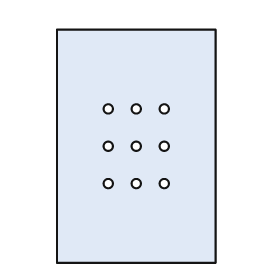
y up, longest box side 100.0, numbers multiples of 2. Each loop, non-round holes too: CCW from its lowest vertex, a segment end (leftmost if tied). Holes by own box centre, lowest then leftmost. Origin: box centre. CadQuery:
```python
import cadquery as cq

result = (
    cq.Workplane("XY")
    .moveTo(-34.0, -50.0)
    .lineTo(34.0, -50.0)
    .lineTo(34.0, 50.0)
    .lineTo(-34.0, 50.0)
    .close()
    .moveTo(-12.0, -16.0)
    .circle(2.0)
    .moveTo(0.0, -16.0)
    .circle(2.0)
    .moveTo(12.0, -16.0)
    .circle(2.0)
    .moveTo(-12.0, 0.0)
    .circle(2.0)
    .moveTo(0.0, 0.0)
    .circle(2.0)
    .moveTo(12.0, 0.0)
    .circle(2.0)
    .moveTo(-12.0, 16.0)
    .circle(2.0)
    .moveTo(0.0, 16.0)
    .circle(2.0)
    .moveTo(12.0, 16.0)
    .circle(2.0)
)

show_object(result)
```